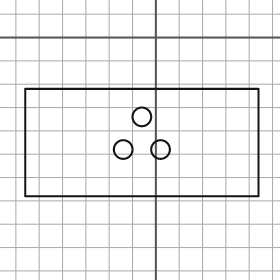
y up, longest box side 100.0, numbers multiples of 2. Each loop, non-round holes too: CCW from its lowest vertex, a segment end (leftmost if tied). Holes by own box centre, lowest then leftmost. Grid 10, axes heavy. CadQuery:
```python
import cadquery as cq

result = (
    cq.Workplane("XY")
    .moveTo(-56.0, -68.0)
    .lineTo(44.0, -68.0)
    .lineTo(44.0, -22.0)
    .lineTo(-56.0, -22.0)
    .close()
    .moveTo(-14.0, -48.0)
    .circle(4.0)
    .moveTo(2.0, -48.0)
    .circle(4.0)
    .moveTo(-6.0, -34.0)
    .circle(4.0)
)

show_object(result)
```